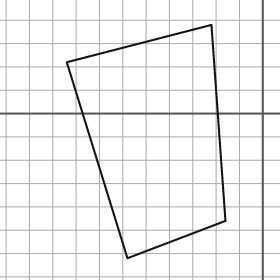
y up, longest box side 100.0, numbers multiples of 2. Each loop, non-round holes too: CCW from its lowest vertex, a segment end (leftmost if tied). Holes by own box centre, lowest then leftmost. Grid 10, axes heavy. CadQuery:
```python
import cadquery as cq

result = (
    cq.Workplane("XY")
    .moveTo(-58.0, -62.0)
    .lineTo(-16.0, -46.0)
    .lineTo(-22.0, 38.0)
    .lineTo(-84.0, 22.0)
    .close()
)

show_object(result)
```